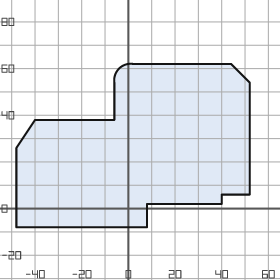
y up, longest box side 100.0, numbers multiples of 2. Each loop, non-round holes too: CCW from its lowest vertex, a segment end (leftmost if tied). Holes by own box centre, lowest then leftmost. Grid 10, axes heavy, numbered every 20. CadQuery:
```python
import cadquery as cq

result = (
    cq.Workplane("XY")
    .moveTo(-48.0, -8.0)
    .lineTo(8.0, -8.0)
    .lineTo(8.0, 2.0)
    .lineTo(40.0, 2.0)
    .lineTo(40.0, 6.0)
    .lineTo(52.0, 6.0)
    .lineTo(52.0, 54.0)
    .lineTo(44.0, 62.0)
    .lineTo(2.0, 62.0)
    .threePointArc((-4.0, 60.0), (-6.0, 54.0))
    .lineTo(-6.0, 38.0)
    .lineTo(-40.0, 38.0)
    .lineTo(-48.0, 26.0)
    .close()
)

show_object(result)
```